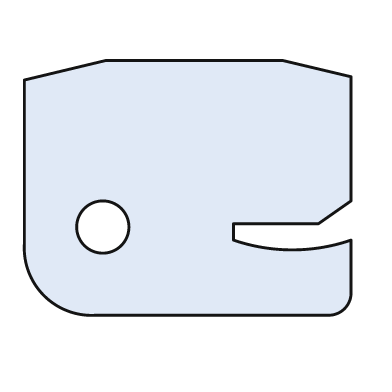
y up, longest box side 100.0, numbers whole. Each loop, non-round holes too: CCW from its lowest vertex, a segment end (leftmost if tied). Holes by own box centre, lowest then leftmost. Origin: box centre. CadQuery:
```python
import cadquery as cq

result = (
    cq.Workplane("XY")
    .moveTo(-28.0, -39.0)
    .lineTo(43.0, -39.0)
    .threePointArc((48.0, -37.0), (50.0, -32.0))
    .lineTo(50.0, -16.0)
    .threePointArc((32.0, -19.0), (14.0, -16.0))
    .lineTo(14.0, -11.0)
    .lineTo(40.0, -11.0)
    .lineTo(50.0, -4.0)
    .lineTo(50.0, 34.0)
    .lineTo(29.0, 39.0)
    .lineTo(-25.0, 39.0)
    .lineTo(-50.0, 33.0)
    .lineTo(-50.0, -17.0)
    .threePointArc((-44.0, -33.0), (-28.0, -39.0))
    .close()
    .moveTo(-26.0, -12.0)
    .circle(8.0)
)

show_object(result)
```